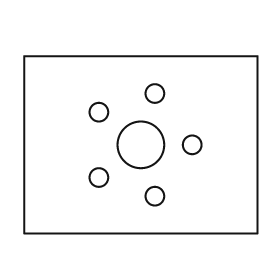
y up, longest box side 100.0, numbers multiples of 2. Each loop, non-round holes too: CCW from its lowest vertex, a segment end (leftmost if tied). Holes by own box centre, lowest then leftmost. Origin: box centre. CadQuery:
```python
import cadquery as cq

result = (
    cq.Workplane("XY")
    .moveTo(-50.0, -38.0)
    .lineTo(50.0, -38.0)
    .lineTo(50.0, 38.0)
    .lineTo(-50.0, 38.0)
    .close()
    .moveTo(6.0, -22.0)
    .circle(4.0)
    .moveTo(-18.0, -14.0)
    .circle(4.0)
    .moveTo(0.0, 0.0)
    .circle(10.0)
    .moveTo(22.0, 0.0)
    .circle(4.0)
    .moveTo(-18.0, 14.0)
    .circle(4.0)
    .moveTo(6.0, 22.0)
    .circle(4.0)
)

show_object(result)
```